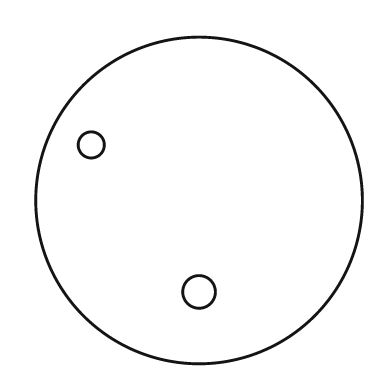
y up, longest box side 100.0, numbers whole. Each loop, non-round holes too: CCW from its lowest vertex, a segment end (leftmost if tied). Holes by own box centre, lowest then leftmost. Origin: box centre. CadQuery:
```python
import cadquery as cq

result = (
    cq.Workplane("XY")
    .moveTo(0.0, 0.0)
    .circle(50.0)
    .moveTo(0.0, -28.0)
    .circle(5.0)
    .moveTo(-33.0, 17.0)
    .circle(4.0)
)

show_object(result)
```